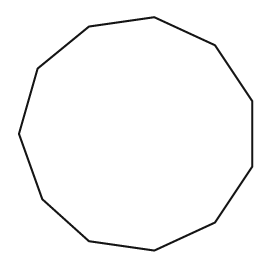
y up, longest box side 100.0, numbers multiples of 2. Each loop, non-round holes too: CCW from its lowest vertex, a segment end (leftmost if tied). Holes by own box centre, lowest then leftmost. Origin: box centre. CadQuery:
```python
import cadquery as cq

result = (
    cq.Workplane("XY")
    .moveTo(8.0, -50.0)
    .lineTo(34.0, -38.0)
    .lineTo(50.0, -14.0)
    .lineTo(50.0, 14.0)
    .lineTo(34.0, 38.0)
    .lineTo(8.0, 50.0)
    .lineTo(-20.0, 46.0)
    .lineTo(-42.0, 28.0)
    .lineTo(-50.0, 0.0)
    .lineTo(-40.0, -28.0)
    .lineTo(-20.0, -46.0)
    .close()
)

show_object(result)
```